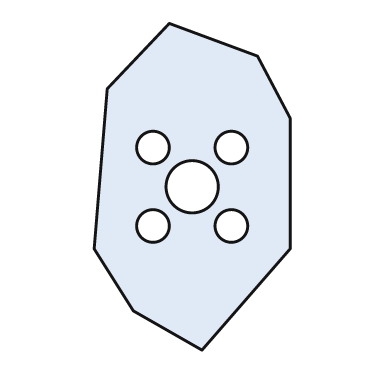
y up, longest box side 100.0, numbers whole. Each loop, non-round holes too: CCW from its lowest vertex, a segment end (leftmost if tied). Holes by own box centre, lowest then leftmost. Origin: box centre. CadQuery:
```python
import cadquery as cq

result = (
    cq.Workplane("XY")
    .moveTo(3.0, -50.0)
    .lineTo(30.0, -19.0)
    .lineTo(30.0, 21.0)
    .lineTo(20.0, 40.0)
    .lineTo(-7.0, 50.0)
    .lineTo(-26.0, 30.0)
    .lineTo(-30.0, -19.0)
    .lineTo(-18.0, -38.0)
    .close()
    .moveTo(-12.0, -12.0)
    .circle(5.0)
    .moveTo(12.0, -12.0)
    .circle(5.0)
    .moveTo(0.0, 0.0)
    .circle(8.0)
    .moveTo(-12.0, 12.0)
    .circle(5.0)
    .moveTo(12.0, 12.0)
    .circle(5.0)
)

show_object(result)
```